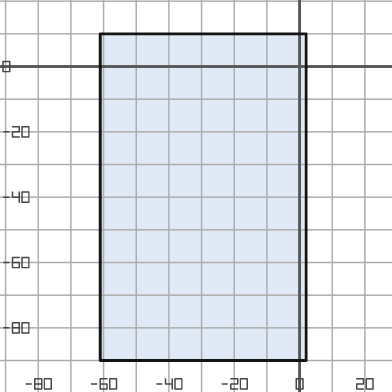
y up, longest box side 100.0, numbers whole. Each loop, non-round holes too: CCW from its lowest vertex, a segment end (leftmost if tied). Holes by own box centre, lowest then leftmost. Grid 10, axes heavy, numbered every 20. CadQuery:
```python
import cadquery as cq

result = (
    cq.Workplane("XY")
    .moveTo(-61.0, -90.0)
    .lineTo(2.0, -90.0)
    .lineTo(2.0, 10.0)
    .lineTo(-61.0, 10.0)
    .close()
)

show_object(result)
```